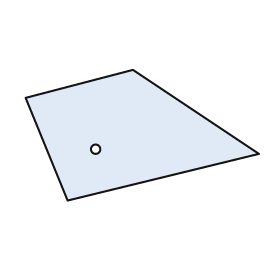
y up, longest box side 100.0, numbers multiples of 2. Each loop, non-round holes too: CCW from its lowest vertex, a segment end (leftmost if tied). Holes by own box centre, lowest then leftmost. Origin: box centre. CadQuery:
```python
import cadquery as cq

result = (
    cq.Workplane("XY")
    .moveTo(-32.0, -28.0)
    .lineTo(50.0, -8.0)
    .lineTo(-4.0, 28.0)
    .lineTo(-50.0, 16.0)
    .close()
    .moveTo(-20.0, -6.0)
    .circle(2.0)
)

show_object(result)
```